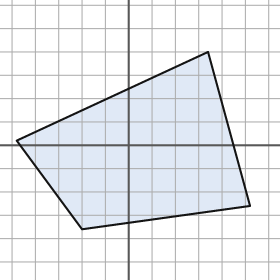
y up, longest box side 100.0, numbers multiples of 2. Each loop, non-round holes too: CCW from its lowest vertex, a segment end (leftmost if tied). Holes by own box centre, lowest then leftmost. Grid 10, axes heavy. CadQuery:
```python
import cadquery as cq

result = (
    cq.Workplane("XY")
    .moveTo(-20.0, -36.0)
    .lineTo(52.0, -26.0)
    .lineTo(34.0, 40.0)
    .lineTo(-48.0, 2.0)
    .close()
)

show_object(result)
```